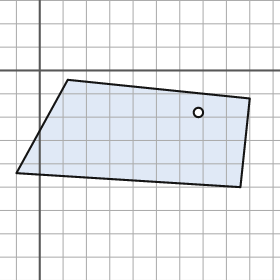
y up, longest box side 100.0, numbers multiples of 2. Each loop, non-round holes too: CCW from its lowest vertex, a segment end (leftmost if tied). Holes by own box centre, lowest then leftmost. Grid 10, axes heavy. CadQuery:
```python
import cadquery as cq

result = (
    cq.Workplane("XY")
    .moveTo(86.0, -50.0)
    .lineTo(90.0, -12.0)
    .lineTo(12.0, -4.0)
    .lineTo(-10.0, -44.0)
    .close()
    .moveTo(68.0, -18.0)
    .circle(2.0)
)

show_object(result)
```